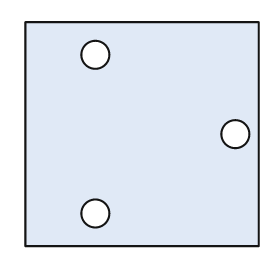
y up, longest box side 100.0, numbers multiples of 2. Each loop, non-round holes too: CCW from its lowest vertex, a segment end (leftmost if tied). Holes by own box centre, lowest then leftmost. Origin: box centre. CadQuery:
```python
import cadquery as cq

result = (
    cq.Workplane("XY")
    .moveTo(-50.0, -48.0)
    .lineTo(50.0, -48.0)
    .lineTo(50.0, 48.0)
    .lineTo(-50.0, 48.0)
    .close()
    .moveTo(-20.0, -34.0)
    .circle(6.0)
    .moveTo(40.0, 0.0)
    .circle(6.0)
    .moveTo(-20.0, 34.0)
    .circle(6.0)
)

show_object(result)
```